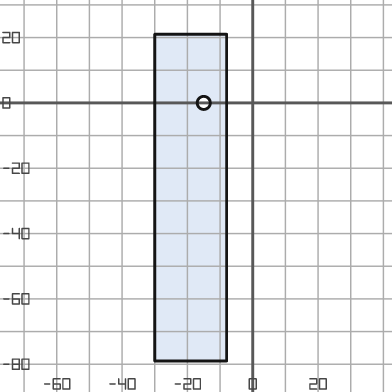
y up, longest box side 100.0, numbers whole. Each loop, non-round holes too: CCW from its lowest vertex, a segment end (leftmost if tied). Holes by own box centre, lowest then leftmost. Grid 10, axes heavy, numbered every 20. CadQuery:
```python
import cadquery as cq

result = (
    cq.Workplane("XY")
    .moveTo(-30.0, -79.0)
    .lineTo(-8.0, -79.0)
    .lineTo(-8.0, 21.0)
    .lineTo(-30.0, 21.0)
    .close()
    .moveTo(-15.0, 0.0)
    .circle(2.0)
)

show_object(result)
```